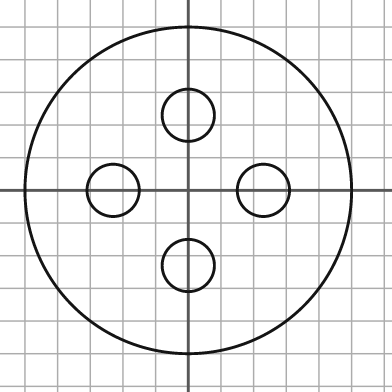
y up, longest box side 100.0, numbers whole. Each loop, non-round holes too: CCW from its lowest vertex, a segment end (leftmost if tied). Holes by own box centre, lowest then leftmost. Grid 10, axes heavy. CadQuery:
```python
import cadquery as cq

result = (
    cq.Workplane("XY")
    .moveTo(0.0, 0.0)
    .circle(50.0)
    .moveTo(0.0, -23.0)
    .circle(8.0)
    .moveTo(-23.0, 0.0)
    .circle(8.0)
    .moveTo(23.0, 0.0)
    .circle(8.0)
    .moveTo(0.0, 23.0)
    .circle(8.0)
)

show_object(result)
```